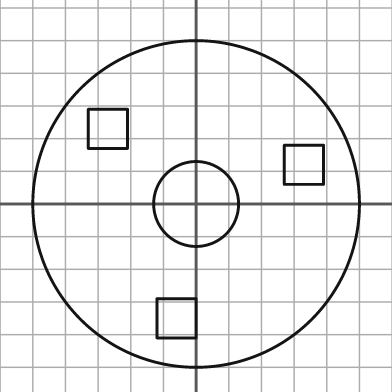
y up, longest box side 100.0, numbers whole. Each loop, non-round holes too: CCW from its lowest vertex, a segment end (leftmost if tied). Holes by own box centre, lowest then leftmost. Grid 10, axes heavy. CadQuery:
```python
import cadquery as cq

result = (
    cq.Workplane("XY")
    .moveTo(0.0, 0.0)
    .circle(50.0)
    .moveTo(-12.0, -41.0)
    .lineTo(0.0, -41.0)
    .lineTo(0.0, -29.0)
    .lineTo(-12.0, -29.0)
    .close()
    .moveTo(0.0, 0.0)
    .circle(13.0)
    .moveTo(27.0, 6.0)
    .lineTo(39.0, 6.0)
    .lineTo(39.0, 18.0)
    .lineTo(27.0, 18.0)
    .close()
    .moveTo(-33.0, 17.0)
    .lineTo(-21.0, 17.0)
    .lineTo(-21.0, 29.0)
    .lineTo(-33.0, 29.0)
    .close()
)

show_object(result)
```